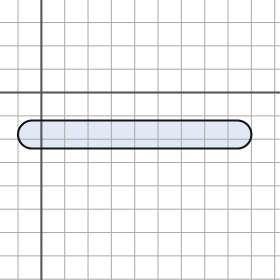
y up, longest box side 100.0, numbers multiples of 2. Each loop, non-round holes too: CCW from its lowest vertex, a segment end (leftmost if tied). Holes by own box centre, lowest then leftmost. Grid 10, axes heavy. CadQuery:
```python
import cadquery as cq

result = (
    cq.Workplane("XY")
    .moveTo(-4.0, -24.0)
    .lineTo(84.0, -24.0)
    .threePointArc((90.0, -18.0), (84.0, -12.0))
    .lineTo(-4.0, -12.0)
    .threePointArc((-10.0, -18.0), (-4.0, -24.0))
    .close()
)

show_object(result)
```